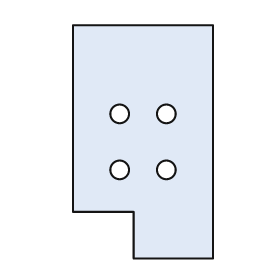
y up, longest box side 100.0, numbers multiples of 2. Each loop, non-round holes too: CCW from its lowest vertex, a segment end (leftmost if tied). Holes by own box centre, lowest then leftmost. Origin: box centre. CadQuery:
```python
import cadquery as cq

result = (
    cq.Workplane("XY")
    .moveTo(-4.0, -50.0)
    .lineTo(30.0, -50.0)
    .lineTo(30.0, 50.0)
    .lineTo(-30.0, 50.0)
    .lineTo(-30.0, -30.0)
    .lineTo(-4.0, -30.0)
    .close()
    .moveTo(-10.0, -12.0)
    .circle(4.0)
    .moveTo(10.0, -12.0)
    .circle(4.0)
    .moveTo(-10.0, 12.0)
    .circle(4.0)
    .moveTo(10.0, 12.0)
    .circle(4.0)
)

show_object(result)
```